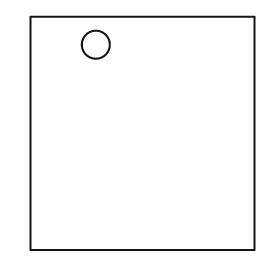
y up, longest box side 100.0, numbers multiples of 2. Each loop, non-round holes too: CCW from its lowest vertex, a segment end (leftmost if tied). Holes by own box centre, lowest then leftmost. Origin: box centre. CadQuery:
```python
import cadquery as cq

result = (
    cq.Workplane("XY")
    .moveTo(-48.0, -50.0)
    .lineTo(48.0, -50.0)
    .lineTo(48.0, 50.0)
    .lineTo(-48.0, 50.0)
    .close()
    .moveTo(-20.0, 38.0)
    .circle(6.0)
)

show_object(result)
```